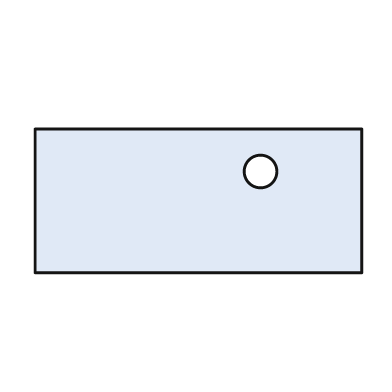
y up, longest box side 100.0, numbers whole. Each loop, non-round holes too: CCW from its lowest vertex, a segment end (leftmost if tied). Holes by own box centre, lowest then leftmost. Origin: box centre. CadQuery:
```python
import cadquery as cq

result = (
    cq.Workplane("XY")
    .moveTo(-50.0, -22.0)
    .lineTo(50.0, -22.0)
    .lineTo(50.0, 22.0)
    .lineTo(-50.0, 22.0)
    .close()
    .moveTo(19.0, 9.0)
    .circle(5.0)
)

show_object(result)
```